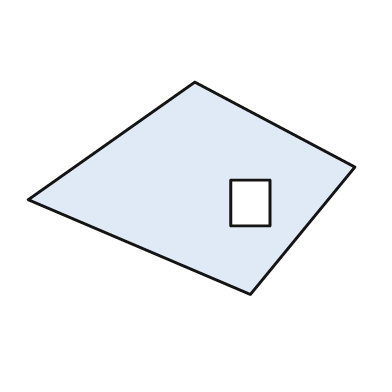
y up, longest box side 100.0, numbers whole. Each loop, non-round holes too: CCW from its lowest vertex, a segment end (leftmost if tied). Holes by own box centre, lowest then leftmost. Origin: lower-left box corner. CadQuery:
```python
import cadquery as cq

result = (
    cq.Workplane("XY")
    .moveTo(68.0, 0.0)
    .lineTo(100.0, 39.0)
    .lineTo(51.0, 65.0)
    .lineTo(0.0, 29.0)
    .close()
    .moveTo(62.0, 21.0)
    .lineTo(74.0, 21.0)
    .lineTo(74.0, 35.0)
    .lineTo(62.0, 35.0)
    .close()
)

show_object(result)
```